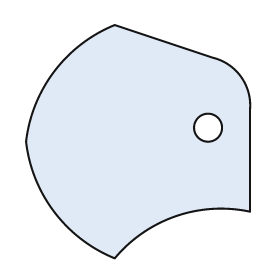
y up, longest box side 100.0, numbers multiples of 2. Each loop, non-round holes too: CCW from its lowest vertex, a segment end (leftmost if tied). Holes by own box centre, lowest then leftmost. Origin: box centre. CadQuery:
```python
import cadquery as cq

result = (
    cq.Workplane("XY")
    .moveTo(-10.0, -50.0)
    .threePointArc((16.0, -32.0), (48.0, -30.0))
    .lineTo(48.0, 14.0)
    .threePointArc((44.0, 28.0), (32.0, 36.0))
    .lineTo(-10.0, 50.0)
    .threePointArc((-36.0, 30.0), (-48.0, 0.0))
    .threePointArc((-36.0, -30.0), (-10.0, -50.0))
    .close()
    .moveTo(30.0, 6.0)
    .circle(6.0)
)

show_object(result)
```